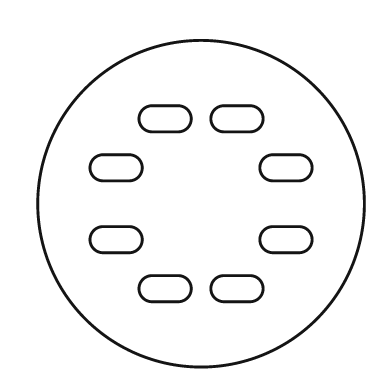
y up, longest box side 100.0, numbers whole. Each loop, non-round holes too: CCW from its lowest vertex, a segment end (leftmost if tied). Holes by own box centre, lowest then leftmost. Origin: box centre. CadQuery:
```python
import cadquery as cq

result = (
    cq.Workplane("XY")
    .moveTo(0.0, 0.0)
    .circle(50.0)
    .moveTo(-15.0, -30.0)
    .lineTo(-7.0, -30.0)
    .threePointArc((-3.0, -26.0), (-7.0, -22.0))
    .lineTo(-15.0, -22.0)
    .threePointArc((-19.0, -26.0), (-15.0, -30.0))
    .close()
    .moveTo(7.0, -30.0)
    .lineTo(15.0, -30.0)
    .threePointArc((19.0, -26.0), (15.0, -22.0))
    .lineTo(7.0, -22.0)
    .threePointArc((3.0, -26.0), (7.0, -30.0))
    .close()
    .moveTo(-30.0, -15.0)
    .lineTo(-22.0, -15.0)
    .threePointArc((-18.0, -11.0), (-22.0, -7.0))
    .lineTo(-30.0, -7.0)
    .threePointArc((-34.0, -11.0), (-30.0, -15.0))
    .close()
    .moveTo(22.0, -15.0)
    .lineTo(30.0, -15.0)
    .threePointArc((34.0, -11.0), (30.0, -7.0))
    .lineTo(22.0, -7.0)
    .threePointArc((18.0, -11.0), (22.0, -15.0))
    .close()
    .moveTo(-30.0, 7.0)
    .lineTo(-22.0, 7.0)
    .threePointArc((-18.0, 11.0), (-22.0, 15.0))
    .lineTo(-30.0, 15.0)
    .threePointArc((-34.0, 11.0), (-30.0, 7.0))
    .close()
    .moveTo(22.0, 7.0)
    .lineTo(30.0, 7.0)
    .threePointArc((34.0, 11.0), (30.0, 15.0))
    .lineTo(22.0, 15.0)
    .threePointArc((18.0, 11.0), (22.0, 7.0))
    .close()
    .moveTo(-15.0, 22.0)
    .lineTo(-7.0, 22.0)
    .threePointArc((-3.0, 26.0), (-7.0, 30.0))
    .lineTo(-15.0, 30.0)
    .threePointArc((-19.0, 26.0), (-15.0, 22.0))
    .close()
    .moveTo(7.0, 22.0)
    .lineTo(15.0, 22.0)
    .threePointArc((19.0, 26.0), (15.0, 30.0))
    .lineTo(7.0, 30.0)
    .threePointArc((3.0, 26.0), (7.0, 22.0))
    .close()
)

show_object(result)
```